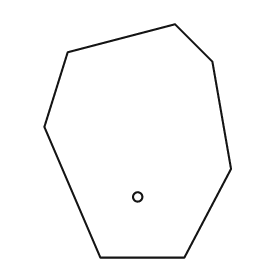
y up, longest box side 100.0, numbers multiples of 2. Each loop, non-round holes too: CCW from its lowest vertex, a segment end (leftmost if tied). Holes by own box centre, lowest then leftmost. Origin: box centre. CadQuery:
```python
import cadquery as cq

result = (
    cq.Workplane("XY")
    .moveTo(-16.0, -50.0)
    .lineTo(20.0, -50.0)
    .lineTo(40.0, -12.0)
    .lineTo(32.0, 34.0)
    .lineTo(16.0, 50.0)
    .lineTo(-30.0, 38.0)
    .lineTo(-40.0, 6.0)
    .close()
    .moveTo(0.0, -24.0)
    .circle(2.0)
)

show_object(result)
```